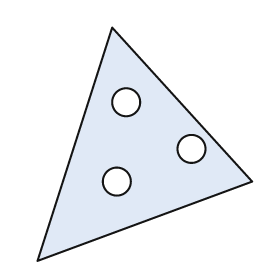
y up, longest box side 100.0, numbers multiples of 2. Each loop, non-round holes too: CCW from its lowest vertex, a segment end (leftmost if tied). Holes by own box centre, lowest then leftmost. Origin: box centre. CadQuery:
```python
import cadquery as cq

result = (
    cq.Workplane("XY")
    .moveTo(-46.0, -50.0)
    .lineTo(46.0, -16.0)
    .lineTo(-14.0, 50.0)
    .close()
    .moveTo(-12.0, -16.0)
    .circle(6.0)
    .moveTo(20.0, -2.0)
    .circle(6.0)
    .moveTo(-8.0, 18.0)
    .circle(6.0)
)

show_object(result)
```